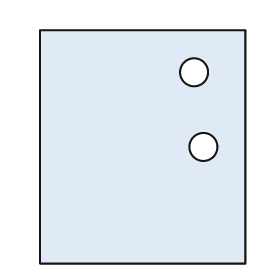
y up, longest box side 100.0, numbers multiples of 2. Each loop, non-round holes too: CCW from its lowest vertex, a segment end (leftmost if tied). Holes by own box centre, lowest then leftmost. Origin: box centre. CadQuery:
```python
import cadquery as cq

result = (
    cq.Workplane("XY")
    .moveTo(-44.0, -50.0)
    .lineTo(44.0, -50.0)
    .lineTo(44.0, 50.0)
    .lineTo(-44.0, 50.0)
    .close()
    .moveTo(26.0, 0.0)
    .circle(6.0)
    .moveTo(22.0, 32.0)
    .circle(6.0)
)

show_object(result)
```